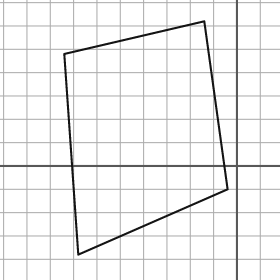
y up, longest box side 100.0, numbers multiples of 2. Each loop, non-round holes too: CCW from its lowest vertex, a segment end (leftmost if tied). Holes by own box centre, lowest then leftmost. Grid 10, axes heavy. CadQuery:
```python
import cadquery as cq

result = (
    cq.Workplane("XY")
    .moveTo(-68.0, -38.0)
    .lineTo(-4.0, -10.0)
    .lineTo(-14.0, 62.0)
    .lineTo(-74.0, 48.0)
    .close()
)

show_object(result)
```